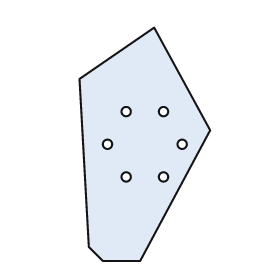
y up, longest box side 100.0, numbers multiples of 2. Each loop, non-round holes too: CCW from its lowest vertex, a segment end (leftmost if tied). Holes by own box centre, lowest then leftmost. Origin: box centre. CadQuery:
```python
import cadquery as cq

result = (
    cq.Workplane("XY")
    .moveTo(-18.0, -50.0)
    .lineTo(-2.0, -50.0)
    .lineTo(28.0, 6.0)
    .lineTo(4.0, 50.0)
    .lineTo(-28.0, 28.0)
    .lineTo(-24.0, -44.0)
    .close()
    .moveTo(-8.0, -14.0)
    .circle(2.0)
    .moveTo(8.0, -14.0)
    .circle(2.0)
    .moveTo(-16.0, 0.0)
    .circle(2.0)
    .moveTo(16.0, 0.0)
    .circle(2.0)
    .moveTo(-8.0, 14.0)
    .circle(2.0)
    .moveTo(8.0, 14.0)
    .circle(2.0)
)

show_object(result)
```